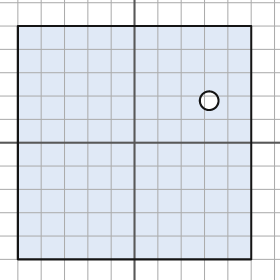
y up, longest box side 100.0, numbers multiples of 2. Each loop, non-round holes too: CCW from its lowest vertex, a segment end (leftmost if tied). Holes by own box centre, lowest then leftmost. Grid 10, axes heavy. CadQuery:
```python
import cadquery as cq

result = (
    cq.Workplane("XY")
    .moveTo(-50.0, -50.0)
    .lineTo(50.0, -50.0)
    .lineTo(50.0, 50.0)
    .lineTo(-50.0, 50.0)
    .close()
    .moveTo(32.0, 18.0)
    .circle(4.0)
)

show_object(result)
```